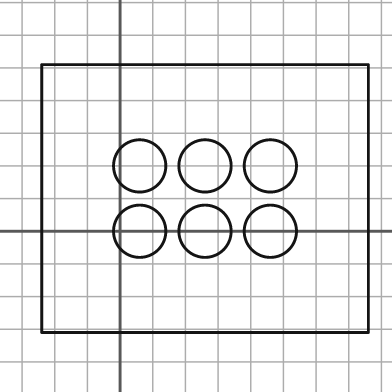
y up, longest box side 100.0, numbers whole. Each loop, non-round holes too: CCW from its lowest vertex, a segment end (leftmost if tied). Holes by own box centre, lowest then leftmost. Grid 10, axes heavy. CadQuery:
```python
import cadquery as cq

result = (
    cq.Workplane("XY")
    .moveTo(-24.0, -31.0)
    .lineTo(76.0, -31.0)
    .lineTo(76.0, 51.0)
    .lineTo(-24.0, 51.0)
    .close()
    .moveTo(6.0, 0.0)
    .circle(8.0)
    .moveTo(26.0, 0.0)
    .circle(8.0)
    .moveTo(46.0, 0.0)
    .circle(8.0)
    .moveTo(6.0, 20.0)
    .circle(8.0)
    .moveTo(26.0, 20.0)
    .circle(8.0)
    .moveTo(46.0, 20.0)
    .circle(8.0)
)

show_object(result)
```